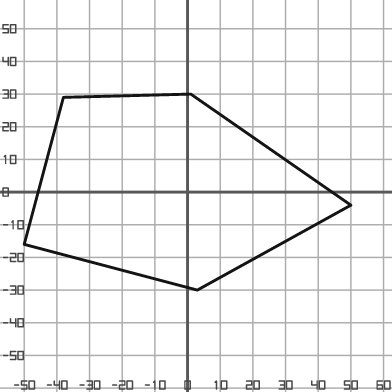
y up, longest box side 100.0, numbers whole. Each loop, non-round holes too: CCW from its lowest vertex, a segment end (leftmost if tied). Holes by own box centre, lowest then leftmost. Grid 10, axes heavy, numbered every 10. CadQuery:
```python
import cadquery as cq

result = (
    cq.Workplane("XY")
    .moveTo(3.0, -30.0)
    .lineTo(50.0, -4.0)
    .lineTo(1.0, 30.0)
    .lineTo(-38.0, 29.0)
    .lineTo(-50.0, -16.0)
    .close()
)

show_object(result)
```